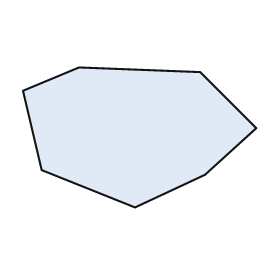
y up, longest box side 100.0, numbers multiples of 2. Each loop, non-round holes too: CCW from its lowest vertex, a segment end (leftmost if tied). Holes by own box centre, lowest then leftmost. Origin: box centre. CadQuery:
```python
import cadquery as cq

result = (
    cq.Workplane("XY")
    .moveTo(-2.0, -30.0)
    .lineTo(28.0, -16.0)
    .lineTo(50.0, 4.0)
    .lineTo(26.0, 28.0)
    .lineTo(-26.0, 30.0)
    .lineTo(-50.0, 20.0)
    .lineTo(-42.0, -14.0)
    .close()
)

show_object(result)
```